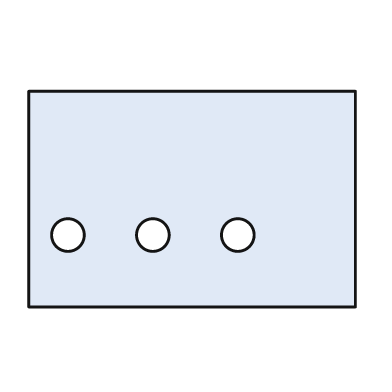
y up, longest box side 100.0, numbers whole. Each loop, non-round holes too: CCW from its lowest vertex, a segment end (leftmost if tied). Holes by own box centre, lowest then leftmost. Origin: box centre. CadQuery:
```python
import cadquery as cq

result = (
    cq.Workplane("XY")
    .moveTo(-50.0, -33.0)
    .lineTo(50.0, -33.0)
    .lineTo(50.0, 33.0)
    .lineTo(-50.0, 33.0)
    .close()
    .moveTo(-38.0, -11.0)
    .circle(5.0)
    .moveTo(-12.0, -11.0)
    .circle(5.0)
    .moveTo(14.0, -11.0)
    .circle(5.0)
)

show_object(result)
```